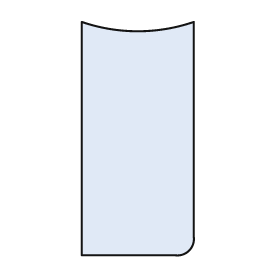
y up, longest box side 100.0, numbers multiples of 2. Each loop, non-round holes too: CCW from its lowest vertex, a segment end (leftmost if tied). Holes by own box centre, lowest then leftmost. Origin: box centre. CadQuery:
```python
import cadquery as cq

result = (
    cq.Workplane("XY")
    .moveTo(-24.0, -50.0)
    .lineTo(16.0, -50.0)
    .threePointArc((22.0, -48.0), (24.0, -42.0))
    .lineTo(24.0, 50.0)
    .threePointArc((0.0, 46.0), (-24.0, 50.0))
    .close()
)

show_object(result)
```